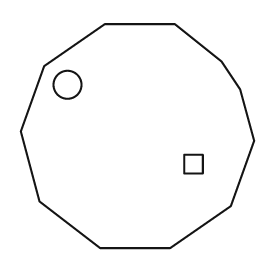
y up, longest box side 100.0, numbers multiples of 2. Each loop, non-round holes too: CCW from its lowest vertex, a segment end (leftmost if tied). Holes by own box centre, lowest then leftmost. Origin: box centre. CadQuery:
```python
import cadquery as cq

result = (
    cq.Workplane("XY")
    .moveTo(-16.0, -48.0)
    .lineTo(14.0, -48.0)
    .lineTo(40.0, -30.0)
    .lineTo(50.0, -2.0)
    .lineTo(44.0, 20.0)
    .lineTo(36.0, 32.0)
    .lineTo(16.0, 48.0)
    .lineTo(-14.0, 48.0)
    .lineTo(-40.0, 30.0)
    .lineTo(-50.0, 2.0)
    .lineTo(-42.0, -28.0)
    .close()
    .moveTo(20.0, -16.0)
    .lineTo(28.0, -16.0)
    .lineTo(28.0, -8.0)
    .lineTo(20.0, -8.0)
    .close()
    .moveTo(-30.0, 22.0)
    .circle(6.0)
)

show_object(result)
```